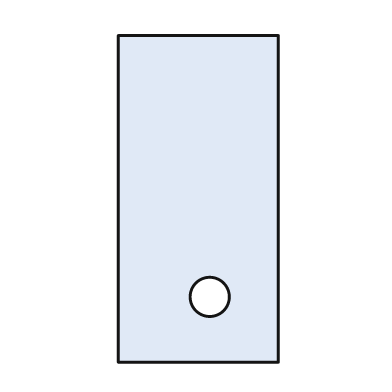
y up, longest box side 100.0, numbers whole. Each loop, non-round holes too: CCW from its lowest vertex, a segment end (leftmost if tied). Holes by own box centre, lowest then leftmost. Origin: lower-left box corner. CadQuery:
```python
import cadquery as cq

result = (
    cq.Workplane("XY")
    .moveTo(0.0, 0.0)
    .lineTo(49.0, 0.0)
    .lineTo(49.0, 100.0)
    .lineTo(0.0, 100.0)
    .close()
    .moveTo(28.0, 20.0)
    .circle(6.0)
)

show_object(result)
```